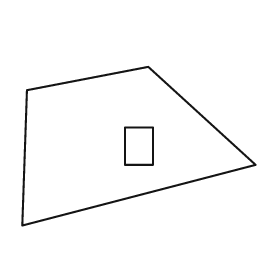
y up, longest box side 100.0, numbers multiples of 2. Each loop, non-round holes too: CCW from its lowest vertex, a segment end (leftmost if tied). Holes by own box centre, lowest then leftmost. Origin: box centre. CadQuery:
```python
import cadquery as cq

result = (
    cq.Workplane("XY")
    .moveTo(-50.0, -34.0)
    .lineTo(50.0, -8.0)
    .lineTo(4.0, 34.0)
    .lineTo(-48.0, 24.0)
    .close()
    .moveTo(-6.0, -8.0)
    .lineTo(6.0, -8.0)
    .lineTo(6.0, 8.0)
    .lineTo(-6.0, 8.0)
    .close()
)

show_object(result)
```